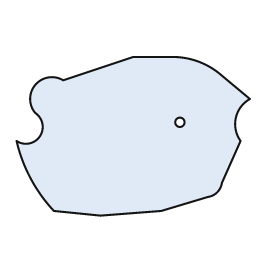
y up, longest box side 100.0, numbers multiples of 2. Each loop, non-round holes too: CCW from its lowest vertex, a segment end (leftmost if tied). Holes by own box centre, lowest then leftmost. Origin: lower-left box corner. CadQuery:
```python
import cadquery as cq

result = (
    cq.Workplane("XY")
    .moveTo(36.0, 0.0)
    .lineTo(62.0, 2.0)
    .lineTo(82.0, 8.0)
    .threePointArc((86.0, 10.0), (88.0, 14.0))
    .lineTo(96.0, 32.0)
    .threePointArc((94.0, 42.0), (100.0, 50.0))
    .lineTo(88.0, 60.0)
    .threePointArc((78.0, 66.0), (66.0, 68.0))
    .lineTo(50.0, 68.0)
    .lineTo(20.0, 58.0)
    .threePointArc((8.0, 56.0), (8.0, 44.0))
    .threePointArc((10.0, 34.0), (0.0, 32.0))
    .threePointArc((6.0, 16.0), (16.0, 2.0))
    .close()
    .moveTo(70.0, 40.0)
    .circle(2.0)
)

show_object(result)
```